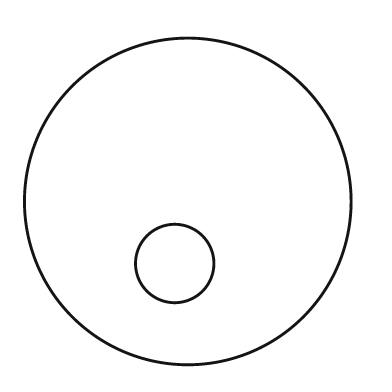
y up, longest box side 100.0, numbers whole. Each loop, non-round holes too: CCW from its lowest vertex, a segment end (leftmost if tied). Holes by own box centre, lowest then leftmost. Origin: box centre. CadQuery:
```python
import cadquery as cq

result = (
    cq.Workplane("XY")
    .moveTo(0.0, 0.0)
    .circle(50.0)
    .moveTo(-4.0, -19.0)
    .circle(12.0)
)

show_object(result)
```